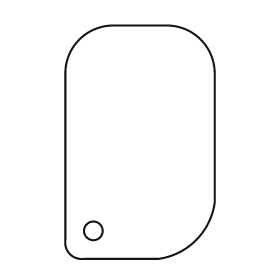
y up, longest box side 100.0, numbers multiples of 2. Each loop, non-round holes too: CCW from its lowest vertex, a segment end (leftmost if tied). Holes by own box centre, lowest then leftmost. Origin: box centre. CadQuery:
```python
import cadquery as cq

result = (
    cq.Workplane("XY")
    .moveTo(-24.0, -50.0)
    .lineTo(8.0, -50.0)
    .threePointArc((24.0, -42.0), (32.0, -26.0))
    .lineTo(32.0, 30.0)
    .threePointArc((26.0, 44.0), (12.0, 50.0))
    .lineTo(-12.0, 50.0)
    .threePointArc((-26.0, 44.0), (-32.0, 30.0))
    .lineTo(-32.0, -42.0)
    .threePointArc((-30.0, -48.0), (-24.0, -50.0))
    .close()
    .moveTo(-20.0, -38.0)
    .circle(4.0)
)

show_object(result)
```